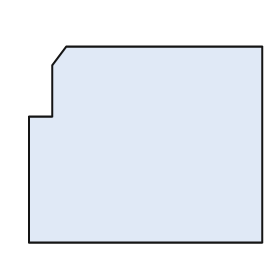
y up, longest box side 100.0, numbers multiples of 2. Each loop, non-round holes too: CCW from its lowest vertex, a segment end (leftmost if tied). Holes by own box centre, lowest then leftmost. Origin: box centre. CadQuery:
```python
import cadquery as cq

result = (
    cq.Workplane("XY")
    .moveTo(-50.0, -42.0)
    .lineTo(50.0, -42.0)
    .lineTo(50.0, 42.0)
    .lineTo(-34.0, 42.0)
    .lineTo(-40.0, 34.0)
    .lineTo(-40.0, 12.0)
    .lineTo(-50.0, 12.0)
    .close()
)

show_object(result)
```